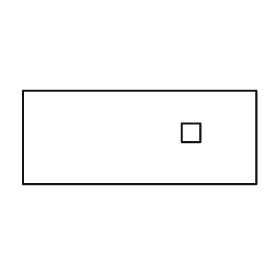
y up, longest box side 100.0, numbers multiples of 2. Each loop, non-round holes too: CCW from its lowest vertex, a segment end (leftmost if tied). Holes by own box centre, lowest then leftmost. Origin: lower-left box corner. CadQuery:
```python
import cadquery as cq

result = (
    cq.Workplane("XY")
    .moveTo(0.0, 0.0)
    .lineTo(100.0, 0.0)
    .lineTo(100.0, 40.0)
    .lineTo(0.0, 40.0)
    .close()
    .moveTo(68.0, 18.0)
    .lineTo(76.0, 18.0)
    .lineTo(76.0, 26.0)
    .lineTo(68.0, 26.0)
    .close()
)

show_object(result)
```